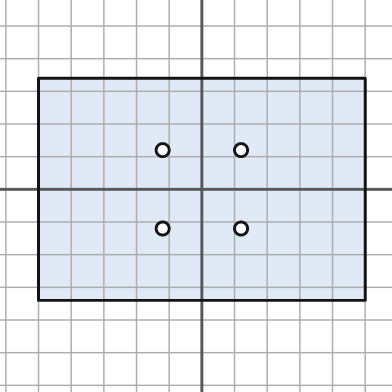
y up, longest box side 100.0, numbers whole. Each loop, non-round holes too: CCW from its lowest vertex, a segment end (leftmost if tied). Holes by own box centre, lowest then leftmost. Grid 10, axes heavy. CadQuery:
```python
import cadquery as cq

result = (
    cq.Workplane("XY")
    .moveTo(-50.0, -34.0)
    .lineTo(50.0, -34.0)
    .lineTo(50.0, 34.0)
    .lineTo(-50.0, 34.0)
    .close()
    .moveTo(-12.0, -12.0)
    .circle(2.0)
    .moveTo(12.0, -12.0)
    .circle(2.0)
    .moveTo(-12.0, 12.0)
    .circle(2.0)
    .moveTo(12.0, 12.0)
    .circle(2.0)
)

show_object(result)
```